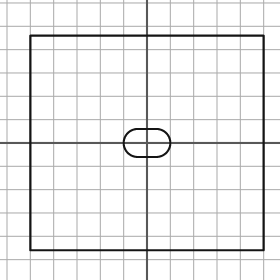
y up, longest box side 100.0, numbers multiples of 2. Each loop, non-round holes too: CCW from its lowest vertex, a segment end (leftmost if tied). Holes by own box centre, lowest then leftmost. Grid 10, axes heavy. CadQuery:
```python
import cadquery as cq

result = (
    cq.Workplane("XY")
    .moveTo(-50.0, -46.0)
    .lineTo(50.0, -46.0)
    .lineTo(50.0, 46.0)
    .lineTo(-50.0, 46.0)
    .close()
    .moveTo(-4.0, -6.0)
    .lineTo(4.0, -6.0)
    .threePointArc((10.0, 0.0), (4.0, 6.0))
    .lineTo(-4.0, 6.0)
    .threePointArc((-10.0, 0.0), (-4.0, -6.0))
    .close()
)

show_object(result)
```